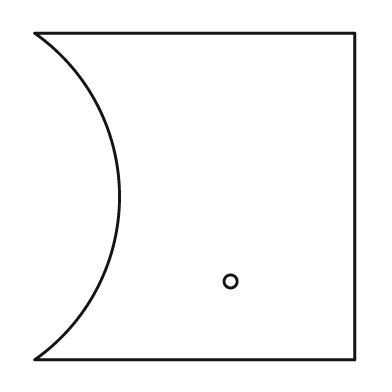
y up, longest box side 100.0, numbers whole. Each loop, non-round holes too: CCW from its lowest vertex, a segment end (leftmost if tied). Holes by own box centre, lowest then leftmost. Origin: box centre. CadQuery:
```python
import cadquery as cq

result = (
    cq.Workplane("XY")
    .moveTo(-49.0, -50.0)
    .lineTo(49.0, -50.0)
    .lineTo(49.0, 50.0)
    .lineTo(-49.0, 50.0)
    .threePointArc((-23.0, 0.0), (-49.0, -50.0))
    .close()
    .moveTo(11.0, -26.0)
    .circle(2.0)
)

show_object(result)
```